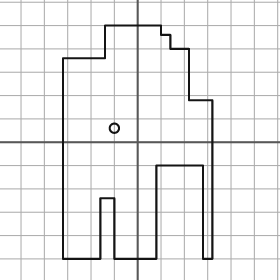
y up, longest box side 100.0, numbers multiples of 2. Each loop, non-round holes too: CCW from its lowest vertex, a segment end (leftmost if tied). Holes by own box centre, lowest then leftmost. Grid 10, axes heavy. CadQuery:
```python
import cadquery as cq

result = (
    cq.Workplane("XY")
    .moveTo(-32.0, -50.0)
    .lineTo(-16.0, -50.0)
    .lineTo(-16.0, -24.0)
    .lineTo(-10.0, -24.0)
    .lineTo(-10.0, -50.0)
    .lineTo(8.0, -50.0)
    .lineTo(8.0, -10.0)
    .lineTo(28.0, -10.0)
    .lineTo(28.0, -50.0)
    .lineTo(32.0, -50.0)
    .lineTo(32.0, 18.0)
    .lineTo(22.0, 18.0)
    .lineTo(22.0, 40.0)
    .lineTo(14.0, 40.0)
    .lineTo(14.0, 46.0)
    .lineTo(10.0, 46.0)
    .lineTo(10.0, 50.0)
    .lineTo(-14.0, 50.0)
    .lineTo(-14.0, 36.0)
    .lineTo(-32.0, 36.0)
    .close()
    .moveTo(-10.0, 6.0)
    .circle(2.0)
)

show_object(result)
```